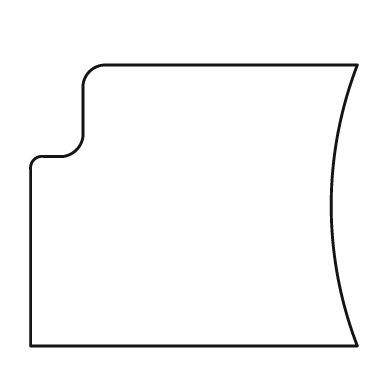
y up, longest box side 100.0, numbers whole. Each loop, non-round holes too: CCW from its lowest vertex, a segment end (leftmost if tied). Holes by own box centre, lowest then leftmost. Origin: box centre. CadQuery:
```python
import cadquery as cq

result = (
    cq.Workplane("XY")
    .moveTo(-50.0, -43.0)
    .lineTo(50.0, -43.0)
    .threePointArc((42.0, 0.0), (50.0, 43.0))
    .lineTo(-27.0, 43.0)
    .threePointArc((-32.0, 41.0), (-34.0, 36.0))
    .lineTo(-34.0, 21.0)
    .threePointArc((-36.0, 17.0), (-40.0, 15.0))
    .lineTo(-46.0, 15.0)
    .threePointArc((-49.0, 14.0), (-50.0, 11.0))
    .close()
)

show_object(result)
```